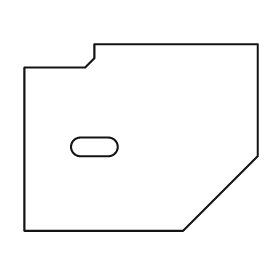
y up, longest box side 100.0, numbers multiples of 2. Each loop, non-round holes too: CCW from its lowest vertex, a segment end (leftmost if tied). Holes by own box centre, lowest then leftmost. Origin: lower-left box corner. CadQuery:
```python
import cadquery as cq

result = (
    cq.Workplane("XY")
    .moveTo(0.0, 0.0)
    .lineTo(68.0, 0.0)
    .lineTo(100.0, 32.0)
    .lineTo(100.0, 80.0)
    .lineTo(30.0, 80.0)
    .lineTo(30.0, 74.0)
    .lineTo(26.0, 70.0)
    .lineTo(0.0, 70.0)
    .close()
    .moveTo(24.0, 32.0)
    .lineTo(36.0, 32.0)
    .threePointArc((40.0, 36.0), (36.0, 40.0))
    .lineTo(24.0, 40.0)
    .threePointArc((20.0, 36.0), (24.0, 32.0))
    .close()
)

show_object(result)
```